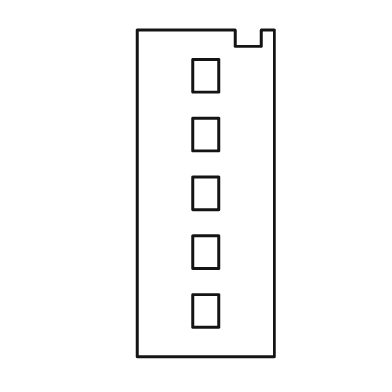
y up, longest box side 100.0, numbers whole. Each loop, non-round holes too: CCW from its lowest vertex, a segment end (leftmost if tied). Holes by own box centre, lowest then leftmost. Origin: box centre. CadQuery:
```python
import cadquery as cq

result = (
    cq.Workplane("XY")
    .moveTo(-21.0, -50.0)
    .lineTo(21.0, -50.0)
    .lineTo(21.0, 50.0)
    .lineTo(17.0, 50.0)
    .lineTo(17.0, 45.0)
    .lineTo(9.0, 45.0)
    .lineTo(9.0, 50.0)
    .lineTo(-21.0, 50.0)
    .close()
    .moveTo(-4.0, -41.0)
    .lineTo(4.0, -41.0)
    .lineTo(4.0, -31.0)
    .lineTo(-4.0, -31.0)
    .close()
    .moveTo(-4.0, -23.0)
    .lineTo(4.0, -23.0)
    .lineTo(4.0, -13.0)
    .lineTo(-4.0, -13.0)
    .close()
    .moveTo(-4.0, -5.0)
    .lineTo(4.0, -5.0)
    .lineTo(4.0, 5.0)
    .lineTo(-4.0, 5.0)
    .close()
    .moveTo(-4.0, 13.0)
    .lineTo(4.0, 13.0)
    .lineTo(4.0, 23.0)
    .lineTo(-4.0, 23.0)
    .close()
    .moveTo(-4.0, 31.0)
    .lineTo(4.0, 31.0)
    .lineTo(4.0, 41.0)
    .lineTo(-4.0, 41.0)
    .close()
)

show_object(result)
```